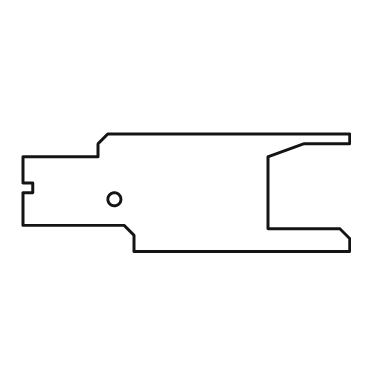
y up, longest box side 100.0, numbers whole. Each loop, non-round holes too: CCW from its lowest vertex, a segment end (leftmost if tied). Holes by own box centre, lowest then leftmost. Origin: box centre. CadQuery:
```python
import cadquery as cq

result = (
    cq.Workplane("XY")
    .moveTo(-16.0, -18.0)
    .lineTo(50.0, -18.0)
    .lineTo(50.0, -14.0)
    .lineTo(47.0, -11.0)
    .lineTo(25.0, -11.0)
    .lineTo(25.0, 11.0)
    .lineTo(36.0, 15.0)
    .lineTo(50.0, 15.0)
    .lineTo(50.0, 18.0)
    .lineTo(-24.0, 18.0)
    .lineTo(-27.0, 15.0)
    .lineTo(-27.0, 11.0)
    .lineTo(-50.0, 11.0)
    .lineTo(-50.0, 3.0)
    .lineTo(-47.0, 3.0)
    .lineTo(-47.0, 0.0)
    .lineTo(-50.0, 0.0)
    .lineTo(-50.0, -10.0)
    .lineTo(-19.0, -10.0)
    .lineTo(-16.0, -13.0)
    .close()
    .moveTo(-22.0, -2.0)
    .circle(2.0)
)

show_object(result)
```